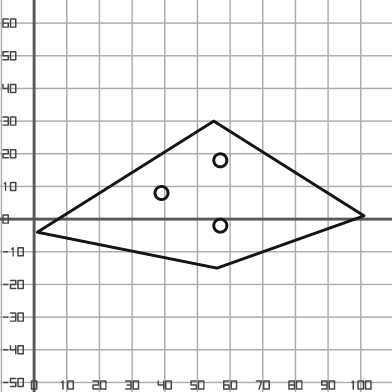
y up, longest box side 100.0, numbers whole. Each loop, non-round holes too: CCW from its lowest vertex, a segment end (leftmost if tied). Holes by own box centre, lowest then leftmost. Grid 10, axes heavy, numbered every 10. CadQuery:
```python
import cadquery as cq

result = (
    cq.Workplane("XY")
    .moveTo(56.0, -15.0)
    .lineTo(101.0, 1.0)
    .lineTo(55.0, 30.0)
    .lineTo(1.0, -4.0)
    .close()
    .moveTo(57.0, -2.0)
    .circle(2.0)
    .moveTo(39.0, 8.0)
    .circle(2.0)
    .moveTo(57.0, 18.0)
    .circle(2.0)
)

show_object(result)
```